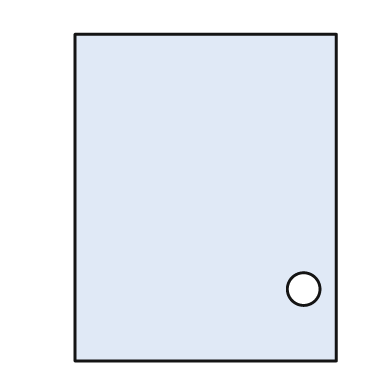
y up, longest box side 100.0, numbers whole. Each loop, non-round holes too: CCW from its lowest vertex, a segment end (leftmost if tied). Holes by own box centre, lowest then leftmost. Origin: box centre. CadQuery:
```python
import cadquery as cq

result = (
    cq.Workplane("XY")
    .moveTo(-40.0, -50.0)
    .lineTo(40.0, -50.0)
    .lineTo(40.0, 50.0)
    .lineTo(-40.0, 50.0)
    .close()
    .moveTo(30.0, -28.0)
    .circle(5.0)
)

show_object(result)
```